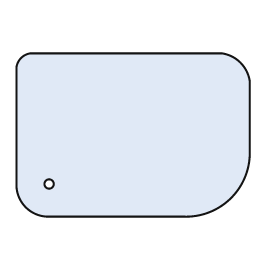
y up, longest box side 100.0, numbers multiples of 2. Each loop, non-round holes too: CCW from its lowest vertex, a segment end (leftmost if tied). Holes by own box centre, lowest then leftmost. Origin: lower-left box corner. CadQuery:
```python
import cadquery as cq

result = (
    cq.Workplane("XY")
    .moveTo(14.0, 0.0)
    .lineTo(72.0, 0.0)
    .threePointArc((92.0, 8.0), (100.0, 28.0))
    .lineTo(100.0, 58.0)
    .threePointArc((96.0, 66.0), (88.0, 70.0))
    .lineTo(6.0, 70.0)
    .threePointArc((2.0, 68.0), (0.0, 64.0))
    .lineTo(0.0, 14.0)
    .threePointArc((4.0, 4.0), (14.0, 0.0))
    .close()
    .moveTo(14.0, 14.0)
    .circle(2.0)
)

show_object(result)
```